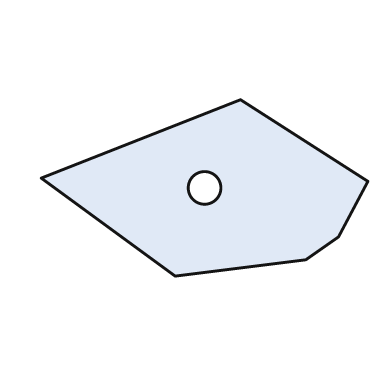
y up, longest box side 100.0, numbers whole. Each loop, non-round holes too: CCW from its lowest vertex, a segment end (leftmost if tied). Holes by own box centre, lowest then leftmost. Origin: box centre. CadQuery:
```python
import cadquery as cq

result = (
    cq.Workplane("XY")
    .moveTo(-9.0, -27.0)
    .lineTo(31.0, -22.0)
    .lineTo(41.0, -15.0)
    .lineTo(50.0, 2.0)
    .lineTo(11.0, 27.0)
    .lineTo(-50.0, 3.0)
    .close()
    .moveTo(0.0, 0.0)
    .circle(5.0)
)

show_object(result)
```